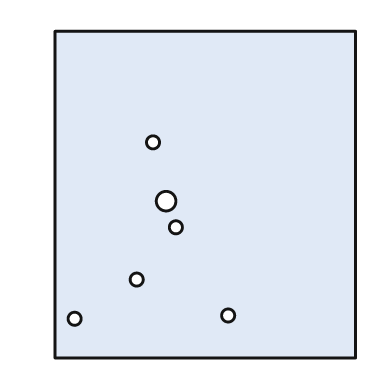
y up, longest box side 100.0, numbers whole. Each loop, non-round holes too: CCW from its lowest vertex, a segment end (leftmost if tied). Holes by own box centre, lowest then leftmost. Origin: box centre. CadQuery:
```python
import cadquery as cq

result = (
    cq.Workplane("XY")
    .moveTo(-46.0, -50.0)
    .lineTo(46.0, -50.0)
    .lineTo(46.0, 50.0)
    .lineTo(-46.0, 50.0)
    .close()
    .moveTo(-40.0, -38.0)
    .circle(2.0)
    .moveTo(7.0, -37.0)
    .circle(2.0)
    .moveTo(-21.0, -26.0)
    .circle(2.0)
    .moveTo(-9.0, -10.0)
    .circle(2.0)
    .moveTo(-12.0, -2.0)
    .circle(3.0)
    .moveTo(-16.0, 16.0)
    .circle(2.0)
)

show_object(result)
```